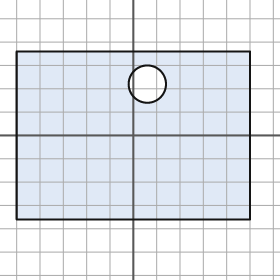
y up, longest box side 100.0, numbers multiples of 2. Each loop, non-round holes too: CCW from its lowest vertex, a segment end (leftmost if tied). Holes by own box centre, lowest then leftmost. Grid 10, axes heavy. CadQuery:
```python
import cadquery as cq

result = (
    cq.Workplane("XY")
    .moveTo(-50.0, -36.0)
    .lineTo(50.0, -36.0)
    .lineTo(50.0, 36.0)
    .lineTo(-50.0, 36.0)
    .close()
    .moveTo(6.0, 22.0)
    .circle(8.0)
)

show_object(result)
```